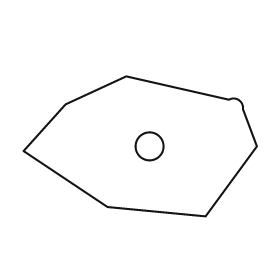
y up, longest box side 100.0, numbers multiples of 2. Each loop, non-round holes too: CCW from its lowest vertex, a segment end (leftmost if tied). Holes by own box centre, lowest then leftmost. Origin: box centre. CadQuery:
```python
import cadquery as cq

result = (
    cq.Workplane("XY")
    .moveTo(28.0, -30.0)
    .lineTo(50.0, 0.0)
    .lineTo(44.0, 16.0)
    .threePointArc((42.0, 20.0), (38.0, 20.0))
    .lineTo(-6.0, 30.0)
    .lineTo(-32.0, 18.0)
    .lineTo(-50.0, -2.0)
    .lineTo(-14.0, -26.0)
    .close()
    .moveTo(4.0, 0.0)
    .circle(6.0)
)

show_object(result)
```